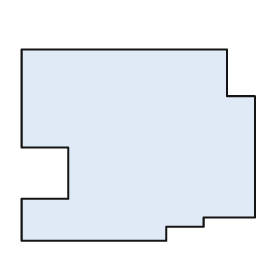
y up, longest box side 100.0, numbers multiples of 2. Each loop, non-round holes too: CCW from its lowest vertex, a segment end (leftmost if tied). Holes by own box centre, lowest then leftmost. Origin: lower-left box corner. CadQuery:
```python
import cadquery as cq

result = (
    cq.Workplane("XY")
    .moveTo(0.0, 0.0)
    .lineTo(62.0, 0.0)
    .lineTo(62.0, 6.0)
    .lineTo(78.0, 6.0)
    .lineTo(78.0, 10.0)
    .lineTo(100.0, 10.0)
    .lineTo(100.0, 62.0)
    .lineTo(88.0, 62.0)
    .lineTo(88.0, 82.0)
    .lineTo(0.0, 82.0)
    .lineTo(0.0, 40.0)
    .lineTo(20.0, 40.0)
    .lineTo(20.0, 18.0)
    .lineTo(0.0, 18.0)
    .close()
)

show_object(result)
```